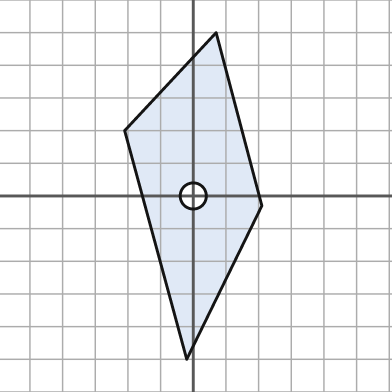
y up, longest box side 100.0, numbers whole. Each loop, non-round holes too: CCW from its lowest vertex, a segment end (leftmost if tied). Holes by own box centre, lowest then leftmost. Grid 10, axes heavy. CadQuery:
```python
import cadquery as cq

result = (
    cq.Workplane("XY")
    .moveTo(-2.0, -50.0)
    .lineTo(21.0, -3.0)
    .lineTo(7.0, 50.0)
    .lineTo(-21.0, 20.0)
    .close()
    .moveTo(0.0, 0.0)
    .circle(4.0)
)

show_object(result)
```